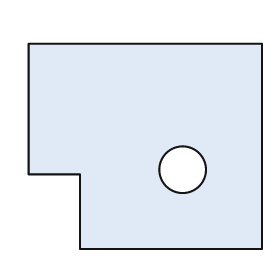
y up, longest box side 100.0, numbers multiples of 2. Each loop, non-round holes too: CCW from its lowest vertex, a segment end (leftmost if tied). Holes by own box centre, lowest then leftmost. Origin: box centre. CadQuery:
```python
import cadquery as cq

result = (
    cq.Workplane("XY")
    .moveTo(-28.0, -44.0)
    .lineTo(50.0, -44.0)
    .lineTo(50.0, 44.0)
    .lineTo(-50.0, 44.0)
    .lineTo(-50.0, -12.0)
    .lineTo(-28.0, -12.0)
    .close()
    .moveTo(16.0, -10.0)
    .circle(10.0)
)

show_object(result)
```